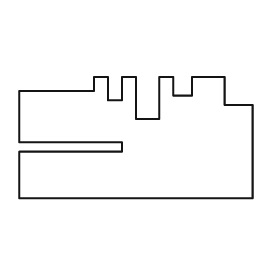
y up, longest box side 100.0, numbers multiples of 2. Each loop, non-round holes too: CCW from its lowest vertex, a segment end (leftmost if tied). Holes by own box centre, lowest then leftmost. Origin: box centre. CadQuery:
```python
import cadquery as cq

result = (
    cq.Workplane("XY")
    .moveTo(-50.0, -26.0)
    .lineTo(50.0, -26.0)
    .lineTo(50.0, 14.0)
    .lineTo(38.0, 14.0)
    .lineTo(38.0, 26.0)
    .lineTo(24.0, 26.0)
    .lineTo(24.0, 18.0)
    .lineTo(16.0, 18.0)
    .lineTo(16.0, 26.0)
    .lineTo(10.0, 26.0)
    .lineTo(10.0, 8.0)
    .lineTo(0.0, 8.0)
    .lineTo(0.0, 26.0)
    .lineTo(-6.0, 26.0)
    .lineTo(-6.0, 16.0)
    .lineTo(-12.0, 16.0)
    .lineTo(-12.0, 26.0)
    .lineTo(-18.0, 26.0)
    .lineTo(-18.0, 20.0)
    .lineTo(-50.0, 20.0)
    .lineTo(-50.0, -2.0)
    .lineTo(-6.0, -2.0)
    .lineTo(-6.0, -6.0)
    .lineTo(-50.0, -6.0)
    .close()
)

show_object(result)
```